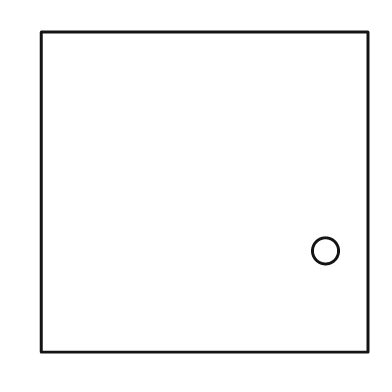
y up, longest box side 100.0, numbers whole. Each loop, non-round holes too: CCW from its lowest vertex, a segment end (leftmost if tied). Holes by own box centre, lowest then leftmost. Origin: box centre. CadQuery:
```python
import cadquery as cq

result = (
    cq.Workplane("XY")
    .moveTo(-50.0, -49.0)
    .lineTo(50.0, -49.0)
    .lineTo(50.0, 49.0)
    .lineTo(-50.0, 49.0)
    .close()
    .moveTo(37.0, -18.0)
    .circle(4.0)
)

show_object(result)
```